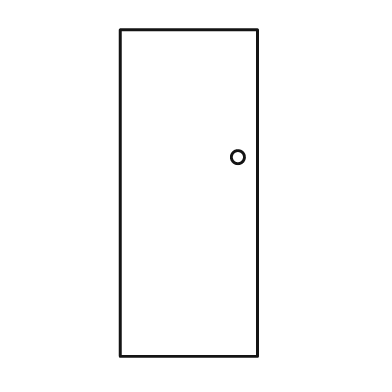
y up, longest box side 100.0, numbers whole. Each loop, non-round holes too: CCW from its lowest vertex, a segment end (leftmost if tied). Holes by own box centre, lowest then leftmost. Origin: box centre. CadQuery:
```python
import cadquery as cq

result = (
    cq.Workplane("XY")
    .moveTo(-21.0, -50.0)
    .lineTo(21.0, -50.0)
    .lineTo(21.0, 50.0)
    .lineTo(-21.0, 50.0)
    .close()
    .moveTo(15.0, 11.0)
    .circle(2.0)
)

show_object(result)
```